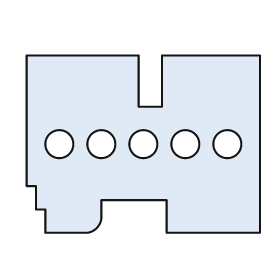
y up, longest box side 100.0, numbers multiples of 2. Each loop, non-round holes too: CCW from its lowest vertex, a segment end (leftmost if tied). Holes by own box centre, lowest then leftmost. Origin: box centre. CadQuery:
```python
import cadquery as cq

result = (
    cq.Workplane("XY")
    .moveTo(-42.0, -38.0)
    .lineTo(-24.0, -38.0)
    .threePointArc((-20.0, -36.0), (-18.0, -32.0))
    .lineTo(-18.0, -24.0)
    .lineTo(10.0, -24.0)
    .lineTo(10.0, -38.0)
    .lineTo(50.0, -38.0)
    .lineTo(50.0, 38.0)
    .lineTo(8.0, 38.0)
    .lineTo(8.0, 16.0)
    .lineTo(-2.0, 16.0)
    .lineTo(-2.0, 38.0)
    .lineTo(-50.0, 38.0)
    .lineTo(-50.0, -18.0)
    .lineTo(-46.0, -18.0)
    .lineTo(-46.0, -28.0)
    .lineTo(-42.0, -28.0)
    .close()
    .moveTo(-36.0, 0.0)
    .circle(6.0)
    .moveTo(-18.0, 0.0)
    .circle(6.0)
    .moveTo(0.0, 0.0)
    .circle(6.0)
    .moveTo(18.0, 0.0)
    .circle(6.0)
    .moveTo(36.0, 0.0)
    .circle(6.0)
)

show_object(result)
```